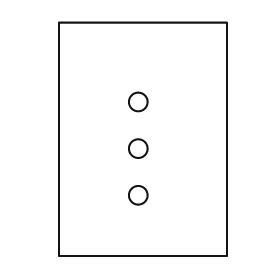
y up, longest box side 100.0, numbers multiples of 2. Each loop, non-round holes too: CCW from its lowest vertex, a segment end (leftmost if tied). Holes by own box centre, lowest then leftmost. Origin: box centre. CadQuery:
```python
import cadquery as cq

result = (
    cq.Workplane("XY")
    .moveTo(-36.0, -50.0)
    .lineTo(36.0, -50.0)
    .lineTo(36.0, 50.0)
    .lineTo(-36.0, 50.0)
    .close()
    .moveTo(-2.0, -24.0)
    .circle(4.0)
    .moveTo(-2.0, -4.0)
    .circle(4.0)
    .moveTo(-2.0, 16.0)
    .circle(4.0)
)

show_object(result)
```